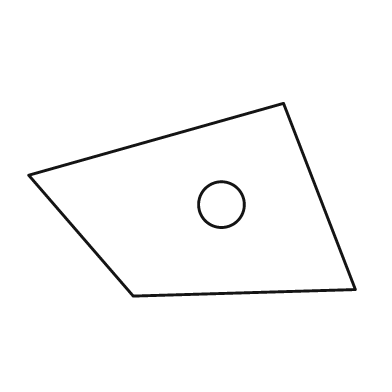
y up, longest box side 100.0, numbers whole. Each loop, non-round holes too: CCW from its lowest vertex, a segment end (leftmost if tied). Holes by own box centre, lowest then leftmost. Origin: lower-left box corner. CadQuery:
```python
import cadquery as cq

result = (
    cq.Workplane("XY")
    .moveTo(32.0, 0.0)
    .lineTo(100.0, 2.0)
    .lineTo(78.0, 59.0)
    .lineTo(0.0, 37.0)
    .close()
    .moveTo(59.0, 28.0)
    .circle(7.0)
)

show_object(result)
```